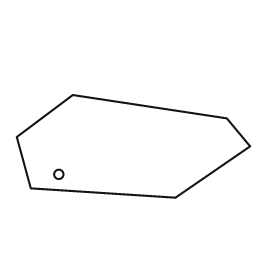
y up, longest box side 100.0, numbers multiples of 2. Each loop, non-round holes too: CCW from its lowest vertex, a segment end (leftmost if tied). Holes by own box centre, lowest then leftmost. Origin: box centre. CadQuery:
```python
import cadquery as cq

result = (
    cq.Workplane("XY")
    .moveTo(18.0, -22.0)
    .lineTo(50.0, 0.0)
    .lineTo(40.0, 12.0)
    .lineTo(-26.0, 22.0)
    .lineTo(-50.0, 4.0)
    .lineTo(-44.0, -18.0)
    .close()
    .moveTo(-32.0, -12.0)
    .circle(2.0)
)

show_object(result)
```